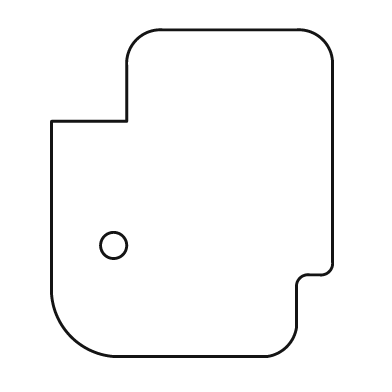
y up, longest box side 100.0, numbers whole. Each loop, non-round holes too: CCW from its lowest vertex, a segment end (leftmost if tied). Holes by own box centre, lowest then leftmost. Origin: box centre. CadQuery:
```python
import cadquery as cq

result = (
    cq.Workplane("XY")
    .moveTo(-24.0, -50.0)
    .lineTo(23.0, -50.0)
    .threePointArc((29.0, -47.0), (32.0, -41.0))
    .lineTo(32.0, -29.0)
    .threePointArc((33.0, -26.0), (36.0, -25.0))
    .lineTo(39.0, -25.0)
    .threePointArc((42.0, -24.0), (43.0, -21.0))
    .lineTo(43.0, 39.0)
    .threePointArc((40.0, 47.0), (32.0, 50.0))
    .lineTo(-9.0, 50.0)
    .threePointArc((-17.0, 47.0), (-20.0, 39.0))
    .lineTo(-20.0, 22.0)
    .lineTo(-43.0, 22.0)
    .lineTo(-43.0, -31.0)
    .threePointArc((-37.0, -44.0), (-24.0, -50.0))
    .close()
    .moveTo(-24.0, -16.0)
    .circle(4.0)
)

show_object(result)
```